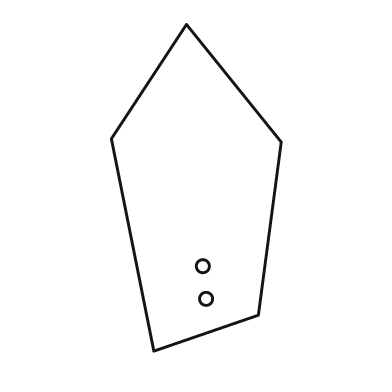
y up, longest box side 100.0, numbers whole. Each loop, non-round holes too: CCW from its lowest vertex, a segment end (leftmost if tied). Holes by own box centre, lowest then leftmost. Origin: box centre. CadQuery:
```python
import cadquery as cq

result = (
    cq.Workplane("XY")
    .moveTo(-13.0, -50.0)
    .lineTo(19.0, -39.0)
    .lineTo(26.0, 14.0)
    .lineTo(-3.0, 50.0)
    .lineTo(-26.0, 15.0)
    .close()
    .moveTo(3.0, -34.0)
    .circle(2.0)
    .moveTo(2.0, -24.0)
    .circle(2.0)
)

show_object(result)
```